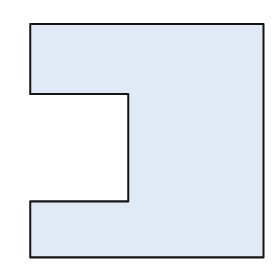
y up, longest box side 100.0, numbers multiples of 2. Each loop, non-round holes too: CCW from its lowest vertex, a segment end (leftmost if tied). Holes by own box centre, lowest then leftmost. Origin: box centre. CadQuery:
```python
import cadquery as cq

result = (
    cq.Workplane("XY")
    .moveTo(-50.0, -50.0)
    .lineTo(50.0, -50.0)
    .lineTo(50.0, 50.0)
    .lineTo(-50.0, 50.0)
    .lineTo(-50.0, 20.0)
    .lineTo(-8.0, 20.0)
    .lineTo(-8.0, -26.0)
    .lineTo(-50.0, -26.0)
    .close()
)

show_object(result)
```